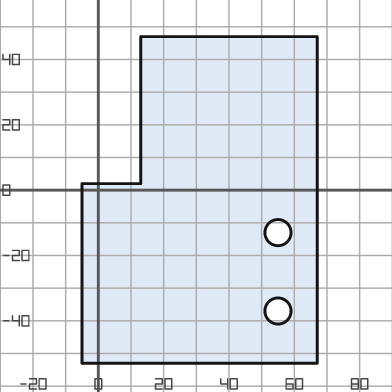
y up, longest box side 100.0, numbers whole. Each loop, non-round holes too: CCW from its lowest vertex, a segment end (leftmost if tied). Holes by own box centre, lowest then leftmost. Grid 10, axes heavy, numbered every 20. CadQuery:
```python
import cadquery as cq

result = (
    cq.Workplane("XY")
    .moveTo(-5.0, -53.0)
    .lineTo(67.0, -53.0)
    .lineTo(67.0, 47.0)
    .lineTo(13.0, 47.0)
    .lineTo(13.0, 2.0)
    .lineTo(-5.0, 2.0)
    .close()
    .moveTo(55.0, -37.0)
    .circle(4.0)
    .moveTo(55.0, -13.0)
    .circle(4.0)
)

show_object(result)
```